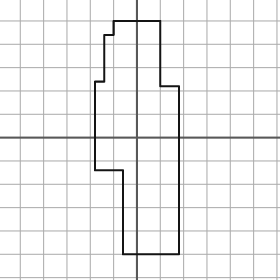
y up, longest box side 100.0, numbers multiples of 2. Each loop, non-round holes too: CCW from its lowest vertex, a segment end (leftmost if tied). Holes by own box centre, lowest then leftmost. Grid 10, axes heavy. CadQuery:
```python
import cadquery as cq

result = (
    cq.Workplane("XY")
    .moveTo(-6.0, -50.0)
    .lineTo(18.0, -50.0)
    .lineTo(18.0, 22.0)
    .lineTo(10.0, 22.0)
    .lineTo(10.0, 50.0)
    .lineTo(-10.0, 50.0)
    .lineTo(-10.0, 44.0)
    .lineTo(-14.0, 44.0)
    .lineTo(-14.0, 24.0)
    .lineTo(-18.0, 24.0)
    .lineTo(-18.0, -14.0)
    .lineTo(-6.0, -14.0)
    .close()
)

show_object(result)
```